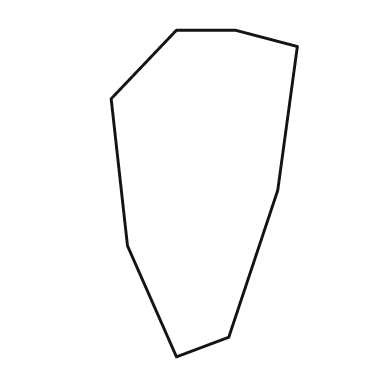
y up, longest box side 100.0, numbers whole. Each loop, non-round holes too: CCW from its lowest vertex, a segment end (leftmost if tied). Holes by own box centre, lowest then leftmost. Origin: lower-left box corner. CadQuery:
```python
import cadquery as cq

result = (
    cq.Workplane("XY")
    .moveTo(20.0, 0.0)
    .lineTo(36.0, 6.0)
    .lineTo(51.0, 51.0)
    .lineTo(57.0, 95.0)
    .lineTo(38.0, 100.0)
    .lineTo(20.0, 100.0)
    .lineTo(0.0, 79.0)
    .lineTo(5.0, 34.0)
    .close()
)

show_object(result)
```